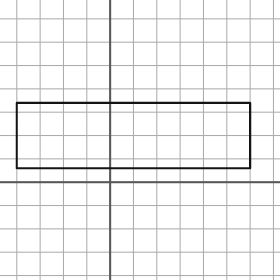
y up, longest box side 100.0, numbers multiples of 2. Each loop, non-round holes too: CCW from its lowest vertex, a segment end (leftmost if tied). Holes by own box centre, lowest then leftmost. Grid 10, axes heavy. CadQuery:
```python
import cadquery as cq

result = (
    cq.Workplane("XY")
    .moveTo(-40.0, 6.0)
    .lineTo(60.0, 6.0)
    .lineTo(60.0, 34.0)
    .lineTo(-40.0, 34.0)
    .close()
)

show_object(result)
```